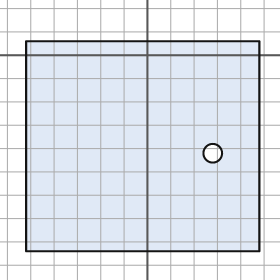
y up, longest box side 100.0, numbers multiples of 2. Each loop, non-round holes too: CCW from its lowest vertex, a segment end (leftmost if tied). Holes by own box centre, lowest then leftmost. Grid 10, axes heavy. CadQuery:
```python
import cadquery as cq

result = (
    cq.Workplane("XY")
    .moveTo(-52.0, -84.0)
    .lineTo(48.0, -84.0)
    .lineTo(48.0, 6.0)
    .lineTo(-52.0, 6.0)
    .close()
    .moveTo(28.0, -42.0)
    .circle(4.0)
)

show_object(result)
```